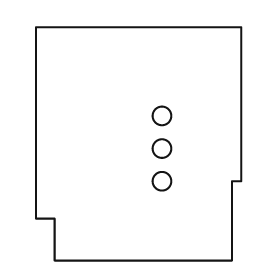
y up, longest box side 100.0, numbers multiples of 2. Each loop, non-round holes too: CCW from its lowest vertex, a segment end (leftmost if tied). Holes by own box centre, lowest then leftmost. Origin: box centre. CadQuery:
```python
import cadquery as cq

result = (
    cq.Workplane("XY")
    .moveTo(-36.0, -50.0)
    .lineTo(40.0, -50.0)
    .lineTo(40.0, -16.0)
    .lineTo(44.0, -16.0)
    .lineTo(44.0, 50.0)
    .lineTo(-44.0, 50.0)
    .lineTo(-44.0, -32.0)
    .lineTo(-36.0, -32.0)
    .close()
    .moveTo(10.0, -16.0)
    .circle(4.0)
    .moveTo(10.0, -2.0)
    .circle(4.0)
    .moveTo(10.0, 12.0)
    .circle(4.0)
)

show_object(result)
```